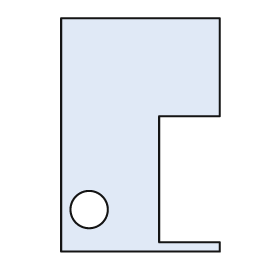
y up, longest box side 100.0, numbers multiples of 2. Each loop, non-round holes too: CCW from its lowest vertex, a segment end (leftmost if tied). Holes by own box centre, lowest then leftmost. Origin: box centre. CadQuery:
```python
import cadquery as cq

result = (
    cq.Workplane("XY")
    .moveTo(-34.0, -50.0)
    .lineTo(34.0, -50.0)
    .lineTo(34.0, -46.0)
    .lineTo(8.0, -46.0)
    .lineTo(8.0, 8.0)
    .lineTo(34.0, 8.0)
    .lineTo(34.0, 50.0)
    .lineTo(-34.0, 50.0)
    .close()
    .moveTo(-22.0, -32.0)
    .circle(8.0)
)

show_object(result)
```